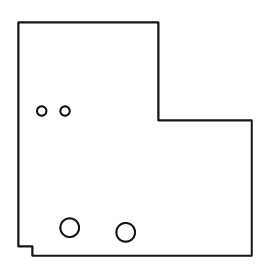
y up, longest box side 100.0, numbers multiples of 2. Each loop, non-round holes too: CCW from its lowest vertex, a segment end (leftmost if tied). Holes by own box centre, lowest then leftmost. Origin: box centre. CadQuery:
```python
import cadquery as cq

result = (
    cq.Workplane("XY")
    .moveTo(-44.0, -50.0)
    .lineTo(50.0, -50.0)
    .lineTo(50.0, 8.0)
    .lineTo(10.0, 8.0)
    .lineTo(10.0, 50.0)
    .lineTo(-50.0, 50.0)
    .lineTo(-50.0, -46.0)
    .lineTo(-44.0, -46.0)
    .close()
    .moveTo(-4.0, -40.0)
    .circle(4.0)
    .moveTo(-28.0, -38.0)
    .circle(4.0)
    .moveTo(-40.0, 12.0)
    .circle(2.0)
    .moveTo(-30.0, 12.0)
    .circle(2.0)
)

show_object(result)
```